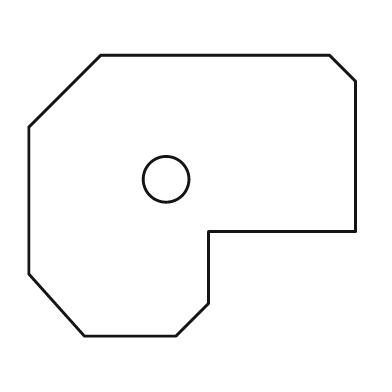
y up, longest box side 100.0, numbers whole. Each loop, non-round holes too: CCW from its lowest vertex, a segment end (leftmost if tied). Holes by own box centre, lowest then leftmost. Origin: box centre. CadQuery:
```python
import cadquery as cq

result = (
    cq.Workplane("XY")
    .moveTo(-33.0, -43.0)
    .lineTo(-5.0, -43.0)
    .lineTo(5.0, -33.0)
    .lineTo(5.0, -11.0)
    .lineTo(50.0, -11.0)
    .lineTo(50.0, 35.0)
    .lineTo(42.0, 43.0)
    .lineTo(-28.0, 43.0)
    .lineTo(-50.0, 21.0)
    .lineTo(-50.0, -24.0)
    .close()
    .moveTo(-8.0, 5.0)
    .circle(7.0)
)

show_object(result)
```